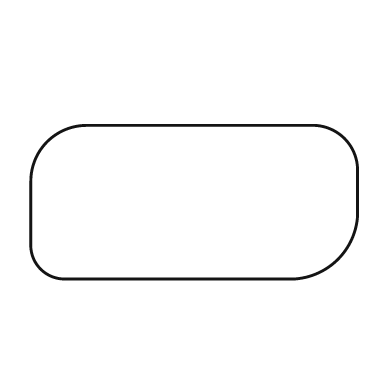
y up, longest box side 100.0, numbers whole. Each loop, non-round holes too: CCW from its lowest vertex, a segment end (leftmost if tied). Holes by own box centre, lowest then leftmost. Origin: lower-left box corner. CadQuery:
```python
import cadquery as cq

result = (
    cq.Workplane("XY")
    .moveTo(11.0, 0.0)
    .lineTo(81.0, 0.0)
    .threePointArc((94.0, 6.0), (100.0, 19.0))
    .lineTo(100.0, 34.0)
    .threePointArc((96.0, 43.0), (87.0, 47.0))
    .lineTo(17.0, 47.0)
    .threePointArc((5.0, 42.0), (0.0, 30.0))
    .lineTo(0.0, 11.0)
    .threePointArc((3.0, 3.0), (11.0, 0.0))
    .close()
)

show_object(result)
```